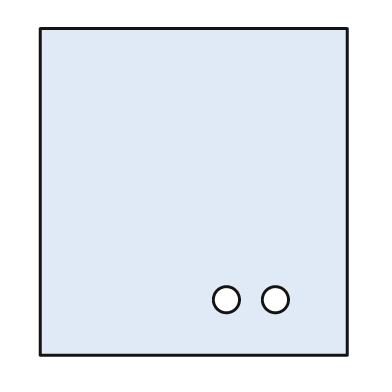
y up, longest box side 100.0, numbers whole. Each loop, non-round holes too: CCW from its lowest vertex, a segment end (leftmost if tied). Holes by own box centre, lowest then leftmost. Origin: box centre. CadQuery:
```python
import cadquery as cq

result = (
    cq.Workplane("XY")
    .moveTo(-47.0, -50.0)
    .lineTo(47.0, -50.0)
    .lineTo(47.0, 50.0)
    .lineTo(-47.0, 50.0)
    .close()
    .moveTo(10.0, -33.0)
    .circle(4.0)
    .moveTo(25.0, -33.0)
    .circle(4.0)
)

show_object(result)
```